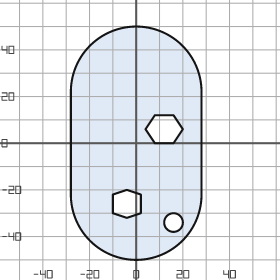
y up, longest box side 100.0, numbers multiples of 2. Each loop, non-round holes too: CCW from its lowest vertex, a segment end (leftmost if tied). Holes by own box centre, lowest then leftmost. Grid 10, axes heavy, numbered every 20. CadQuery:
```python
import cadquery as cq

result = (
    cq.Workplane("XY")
    .moveTo(-28.0, -22.0)
    .threePointArc((0.0, -50.0), (28.0, -22.0))
    .lineTo(28.0, 22.0)
    .threePointArc((0.0, 50.0), (-28.0, 22.0))
    .close()
    .moveTo(16.0, -34.0)
    .circle(4.0)
    .moveTo(-4.0, -32.0)
    .lineTo(2.0, -30.0)
    .lineTo(2.0, -22.0)
    .lineTo(-4.0, -20.0)
    .lineTo(-10.0, -22.0)
    .lineTo(-10.0, -30.0)
    .close()
    .moveTo(8.0, 0.0)
    .lineTo(16.0, 0.0)
    .lineTo(20.0, 6.0)
    .lineTo(16.0, 12.0)
    .lineTo(8.0, 12.0)
    .lineTo(4.0, 6.0)
    .close()
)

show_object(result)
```